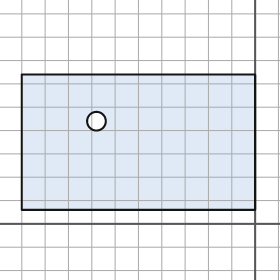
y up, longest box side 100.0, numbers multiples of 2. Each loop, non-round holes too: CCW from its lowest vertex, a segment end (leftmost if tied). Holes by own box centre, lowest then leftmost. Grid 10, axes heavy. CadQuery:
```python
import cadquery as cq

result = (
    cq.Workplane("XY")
    .moveTo(-100.0, 6.0)
    .lineTo(0.0, 6.0)
    .lineTo(0.0, 64.0)
    .lineTo(-100.0, 64.0)
    .close()
    .moveTo(-68.0, 44.0)
    .circle(4.0)
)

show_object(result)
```